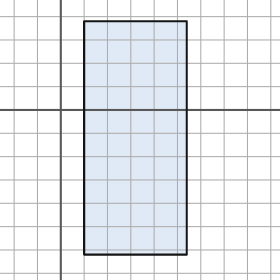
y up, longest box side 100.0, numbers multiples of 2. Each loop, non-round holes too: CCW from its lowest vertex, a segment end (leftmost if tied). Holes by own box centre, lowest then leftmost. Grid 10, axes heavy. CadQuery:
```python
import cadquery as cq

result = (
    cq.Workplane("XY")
    .moveTo(10.0, -62.0)
    .lineTo(54.0, -62.0)
    .lineTo(54.0, 38.0)
    .lineTo(10.0, 38.0)
    .close()
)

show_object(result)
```